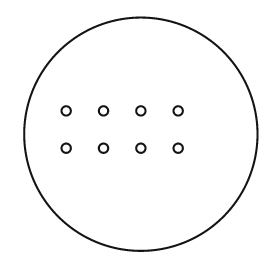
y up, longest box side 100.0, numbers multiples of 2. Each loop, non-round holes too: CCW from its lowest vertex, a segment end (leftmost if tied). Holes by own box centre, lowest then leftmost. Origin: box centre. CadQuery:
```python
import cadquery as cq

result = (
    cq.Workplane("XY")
    .moveTo(0.0, 0.0)
    .circle(50.0)
    .moveTo(-32.0, -6.0)
    .circle(2.0)
    .moveTo(-16.0, -6.0)
    .circle(2.0)
    .moveTo(0.0, -6.0)
    .circle(2.0)
    .moveTo(16.0, -6.0)
    .circle(2.0)
    .moveTo(-32.0, 10.0)
    .circle(2.0)
    .moveTo(-16.0, 10.0)
    .circle(2.0)
    .moveTo(0.0, 10.0)
    .circle(2.0)
    .moveTo(16.0, 10.0)
    .circle(2.0)
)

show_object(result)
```